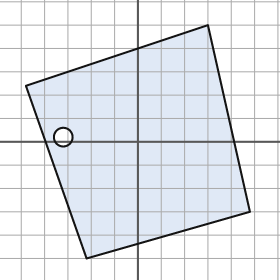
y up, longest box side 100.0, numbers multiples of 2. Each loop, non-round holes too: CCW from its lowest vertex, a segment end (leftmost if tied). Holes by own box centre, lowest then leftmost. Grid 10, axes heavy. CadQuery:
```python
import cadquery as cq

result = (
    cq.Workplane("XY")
    .moveTo(-22.0, -50.0)
    .lineTo(48.0, -30.0)
    .lineTo(30.0, 50.0)
    .lineTo(-48.0, 24.0)
    .close()
    .moveTo(-32.0, 2.0)
    .circle(4.0)
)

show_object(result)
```